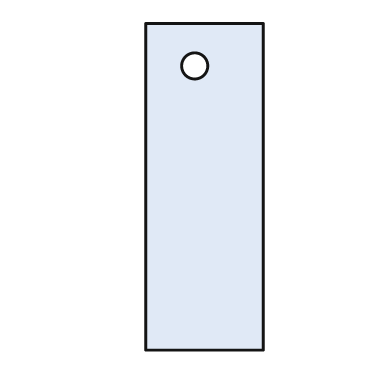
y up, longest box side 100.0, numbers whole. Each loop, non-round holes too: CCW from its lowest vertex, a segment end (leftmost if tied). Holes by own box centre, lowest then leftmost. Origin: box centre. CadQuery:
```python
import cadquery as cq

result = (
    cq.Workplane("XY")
    .moveTo(-18.0, -50.0)
    .lineTo(18.0, -50.0)
    .lineTo(18.0, 50.0)
    .lineTo(-18.0, 50.0)
    .close()
    .moveTo(-3.0, 37.0)
    .circle(4.0)
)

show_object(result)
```